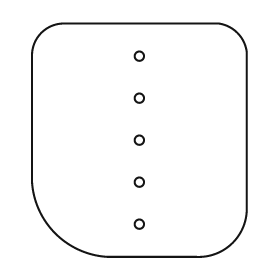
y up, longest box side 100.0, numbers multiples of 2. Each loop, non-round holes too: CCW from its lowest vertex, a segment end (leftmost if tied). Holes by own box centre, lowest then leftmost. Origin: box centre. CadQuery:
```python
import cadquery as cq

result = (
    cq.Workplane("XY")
    .moveTo(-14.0, -50.0)
    .lineTo(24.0, -50.0)
    .threePointArc((40.0, -44.0), (46.0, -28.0))
    .lineTo(46.0, 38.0)
    .threePointArc((42.0, 46.0), (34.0, 50.0))
    .lineTo(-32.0, 50.0)
    .threePointArc((-42.0, 46.0), (-46.0, 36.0))
    .lineTo(-46.0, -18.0)
    .threePointArc((-36.0, -40.0), (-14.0, -50.0))
    .close()
    .moveTo(0.0, -36.0)
    .circle(2.0)
    .moveTo(0.0, -18.0)
    .circle(2.0)
    .moveTo(0.0, 0.0)
    .circle(2.0)
    .moveTo(0.0, 18.0)
    .circle(2.0)
    .moveTo(0.0, 36.0)
    .circle(2.0)
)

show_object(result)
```